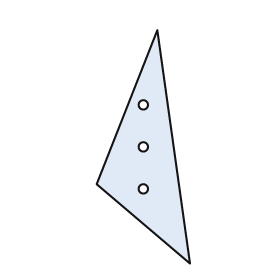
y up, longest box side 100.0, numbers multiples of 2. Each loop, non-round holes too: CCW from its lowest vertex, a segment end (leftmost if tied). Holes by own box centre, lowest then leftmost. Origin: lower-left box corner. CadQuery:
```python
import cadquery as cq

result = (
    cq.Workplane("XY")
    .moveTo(40.0, 0.0)
    .lineTo(26.0, 100.0)
    .lineTo(0.0, 34.0)
    .close()
    .moveTo(20.0, 32.0)
    .circle(2.0)
    .moveTo(20.0, 50.0)
    .circle(2.0)
    .moveTo(20.0, 68.0)
    .circle(2.0)
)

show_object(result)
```